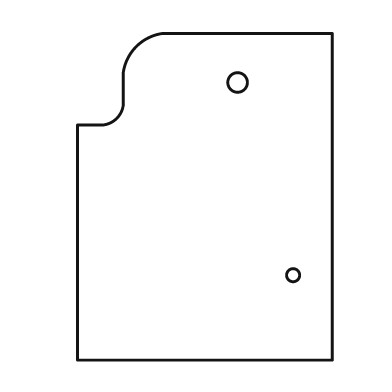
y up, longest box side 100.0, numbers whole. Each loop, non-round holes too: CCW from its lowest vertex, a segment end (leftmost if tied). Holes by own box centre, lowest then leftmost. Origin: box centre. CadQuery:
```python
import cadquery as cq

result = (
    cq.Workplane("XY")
    .moveTo(-39.0, -50.0)
    .lineTo(39.0, -50.0)
    .lineTo(39.0, 50.0)
    .lineTo(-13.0, 50.0)
    .threePointArc((-21.0, 46.0), (-25.0, 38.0))
    .lineTo(-25.0, 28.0)
    .threePointArc((-27.0, 24.0), (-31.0, 22.0))
    .lineTo(-39.0, 22.0)
    .close()
    .moveTo(27.0, -24.0)
    .circle(2.0)
    .moveTo(10.0, 35.0)
    .circle(3.0)
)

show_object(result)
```